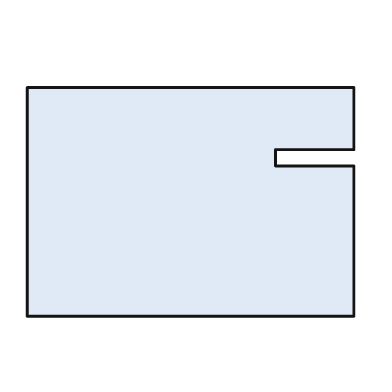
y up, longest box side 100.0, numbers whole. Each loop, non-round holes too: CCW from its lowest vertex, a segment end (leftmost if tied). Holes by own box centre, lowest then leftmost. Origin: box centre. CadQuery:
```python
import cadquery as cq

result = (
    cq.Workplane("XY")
    .moveTo(-50.0, -35.0)
    .lineTo(50.0, -35.0)
    .lineTo(50.0, 11.0)
    .lineTo(26.0, 11.0)
    .lineTo(26.0, 16.0)
    .lineTo(50.0, 16.0)
    .lineTo(50.0, 35.0)
    .lineTo(-50.0, 35.0)
    .close()
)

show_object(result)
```